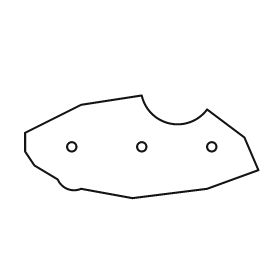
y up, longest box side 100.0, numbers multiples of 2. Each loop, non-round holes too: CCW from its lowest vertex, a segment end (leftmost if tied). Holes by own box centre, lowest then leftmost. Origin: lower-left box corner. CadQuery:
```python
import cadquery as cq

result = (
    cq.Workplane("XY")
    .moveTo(46.0, 0.0)
    .lineTo(78.0, 4.0)
    .lineTo(100.0, 12.0)
    .lineTo(94.0, 26.0)
    .lineTo(78.0, 38.0)
    .threePointArc((62.0, 32.0), (50.0, 44.0))
    .lineTo(24.0, 40.0)
    .lineTo(0.0, 28.0)
    .lineTo(0.0, 20.0)
    .lineTo(4.0, 14.0)
    .lineTo(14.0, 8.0)
    .threePointArc((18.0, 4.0), (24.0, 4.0))
    .close()
    .moveTo(20.0, 22.0)
    .circle(2.0)
    .moveTo(50.0, 22.0)
    .circle(2.0)
    .moveTo(80.0, 22.0)
    .circle(2.0)
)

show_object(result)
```